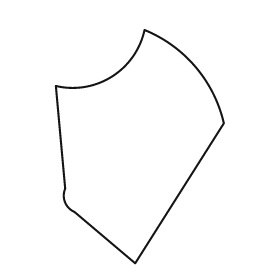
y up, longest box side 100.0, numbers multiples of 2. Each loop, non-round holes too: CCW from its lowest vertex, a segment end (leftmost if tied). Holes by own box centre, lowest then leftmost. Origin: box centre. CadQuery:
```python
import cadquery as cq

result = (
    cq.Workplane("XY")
    .moveTo(-2.0, -50.0)
    .lineTo(36.0, 10.0)
    .threePointArc((24.0, 34.0), (2.0, 50.0))
    .threePointArc((-12.0, 30.0), (-36.0, 26.0))
    .lineTo(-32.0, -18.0)
    .threePointArc((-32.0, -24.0), (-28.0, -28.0))
    .close()
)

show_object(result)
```